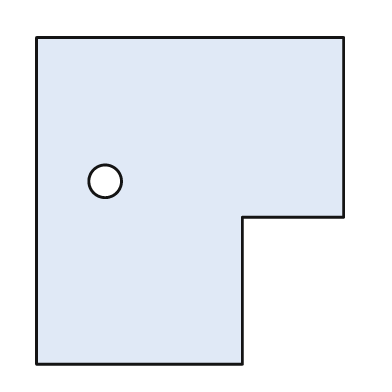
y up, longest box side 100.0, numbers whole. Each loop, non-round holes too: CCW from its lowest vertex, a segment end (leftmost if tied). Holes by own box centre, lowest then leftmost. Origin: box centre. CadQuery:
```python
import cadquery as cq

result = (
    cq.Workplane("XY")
    .moveTo(-47.0, -50.0)
    .lineTo(16.0, -50.0)
    .lineTo(16.0, -5.0)
    .lineTo(47.0, -5.0)
    .lineTo(47.0, 50.0)
    .lineTo(-47.0, 50.0)
    .close()
    .moveTo(-26.0, 6.0)
    .circle(5.0)
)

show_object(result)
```